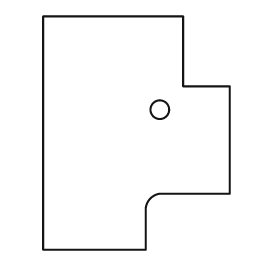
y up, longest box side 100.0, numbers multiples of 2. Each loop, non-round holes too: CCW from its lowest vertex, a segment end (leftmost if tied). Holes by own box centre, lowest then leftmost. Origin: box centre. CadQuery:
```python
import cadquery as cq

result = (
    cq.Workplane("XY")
    .moveTo(-40.0, -50.0)
    .lineTo(4.0, -50.0)
    .lineTo(4.0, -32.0)
    .threePointArc((6.0, -28.0), (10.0, -26.0))
    .lineTo(40.0, -26.0)
    .lineTo(40.0, 20.0)
    .lineTo(20.0, 20.0)
    .lineTo(20.0, 50.0)
    .lineTo(-40.0, 50.0)
    .close()
    .moveTo(10.0, 10.0)
    .circle(4.0)
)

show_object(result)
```